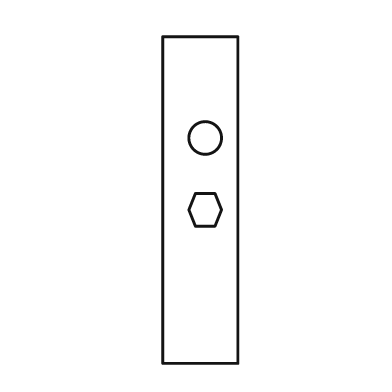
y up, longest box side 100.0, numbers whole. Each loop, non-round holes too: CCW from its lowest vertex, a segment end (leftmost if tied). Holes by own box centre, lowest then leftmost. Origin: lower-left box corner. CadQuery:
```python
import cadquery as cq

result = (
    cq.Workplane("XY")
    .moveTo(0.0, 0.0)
    .lineTo(23.0, 0.0)
    .lineTo(23.0, 100.0)
    .lineTo(0.0, 100.0)
    .close()
    .moveTo(10.0, 42.0)
    .lineTo(16.0, 42.0)
    .lineTo(18.0, 47.0)
    .lineTo(16.0, 52.0)
    .lineTo(10.0, 52.0)
    .lineTo(8.0, 47.0)
    .close()
    .moveTo(13.0, 69.0)
    .circle(5.0)
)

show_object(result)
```